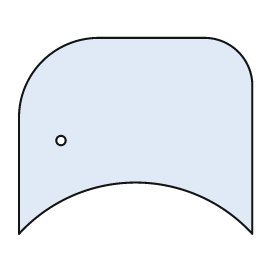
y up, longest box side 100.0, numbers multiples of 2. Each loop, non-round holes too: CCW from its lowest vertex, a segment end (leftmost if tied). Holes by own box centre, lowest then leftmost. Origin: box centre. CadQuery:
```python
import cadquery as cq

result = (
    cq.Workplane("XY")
    .moveTo(-50.0, -42.0)
    .threePointArc((0.0, -20.0), (50.0, -42.0))
    .lineTo(50.0, 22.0)
    .threePointArc((44.0, 36.0), (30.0, 42.0))
    .lineTo(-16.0, 42.0)
    .threePointArc((-40.0, 32.0), (-50.0, 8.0))
    .close()
    .moveTo(-32.0, -2.0)
    .circle(2.0)
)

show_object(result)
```